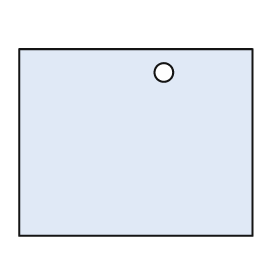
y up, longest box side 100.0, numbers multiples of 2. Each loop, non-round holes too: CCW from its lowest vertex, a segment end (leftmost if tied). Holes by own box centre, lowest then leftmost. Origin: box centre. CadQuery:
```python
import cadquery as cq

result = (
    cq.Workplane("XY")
    .moveTo(-50.0, -40.0)
    .lineTo(50.0, -40.0)
    .lineTo(50.0, 40.0)
    .lineTo(-50.0, 40.0)
    .close()
    .moveTo(12.0, 30.0)
    .circle(4.0)
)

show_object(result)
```